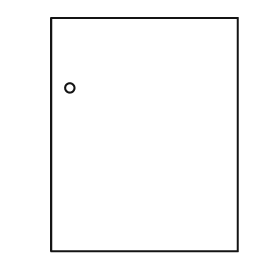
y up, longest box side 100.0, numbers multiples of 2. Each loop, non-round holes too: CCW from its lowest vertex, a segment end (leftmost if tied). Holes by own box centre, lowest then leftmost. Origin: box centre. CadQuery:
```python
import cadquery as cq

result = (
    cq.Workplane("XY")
    .moveTo(-40.0, -50.0)
    .lineTo(40.0, -50.0)
    .lineTo(40.0, 50.0)
    .lineTo(-40.0, 50.0)
    .close()
    .moveTo(-32.0, 20.0)
    .circle(2.0)
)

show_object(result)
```